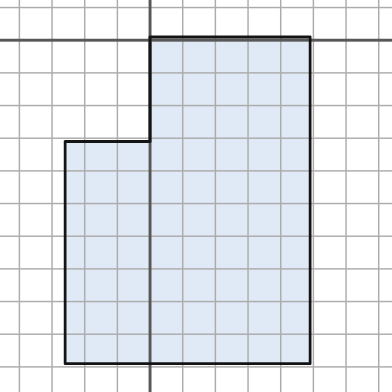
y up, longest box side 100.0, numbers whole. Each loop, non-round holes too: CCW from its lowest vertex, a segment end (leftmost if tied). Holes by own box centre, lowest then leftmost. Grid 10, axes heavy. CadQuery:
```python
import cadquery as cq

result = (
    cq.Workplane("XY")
    .moveTo(-26.0, -99.0)
    .lineTo(49.0, -99.0)
    .lineTo(49.0, 1.0)
    .lineTo(0.0, 1.0)
    .lineTo(0.0, -31.0)
    .lineTo(-26.0, -31.0)
    .close()
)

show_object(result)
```